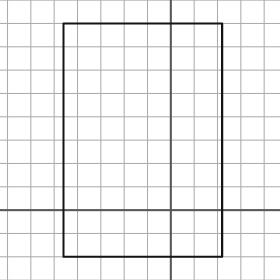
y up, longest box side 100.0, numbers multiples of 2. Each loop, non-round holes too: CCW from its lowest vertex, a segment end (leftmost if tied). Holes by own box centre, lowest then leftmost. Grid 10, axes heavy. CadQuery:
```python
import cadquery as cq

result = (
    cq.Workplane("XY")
    .moveTo(-46.0, -20.0)
    .lineTo(22.0, -20.0)
    .lineTo(22.0, 80.0)
    .lineTo(-46.0, 80.0)
    .close()
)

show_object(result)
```